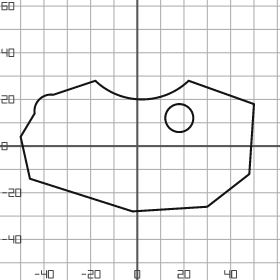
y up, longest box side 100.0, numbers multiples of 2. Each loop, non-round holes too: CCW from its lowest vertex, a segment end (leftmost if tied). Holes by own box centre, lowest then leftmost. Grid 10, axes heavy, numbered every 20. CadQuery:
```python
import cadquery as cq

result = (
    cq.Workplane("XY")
    .moveTo(-2.0, -28.0)
    .lineTo(30.0, -26.0)
    .lineTo(48.0, -12.0)
    .lineTo(50.0, 18.0)
    .lineTo(22.0, 28.0)
    .threePointArc((2.0, 20.0), (-18.0, 28.0))
    .lineTo(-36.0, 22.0)
    .threePointArc((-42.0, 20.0), (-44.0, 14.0))
    .lineTo(-50.0, 4.0)
    .lineTo(-46.0, -14.0)
    .close()
    .moveTo(18.0, 12.0)
    .circle(6.0)
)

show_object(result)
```